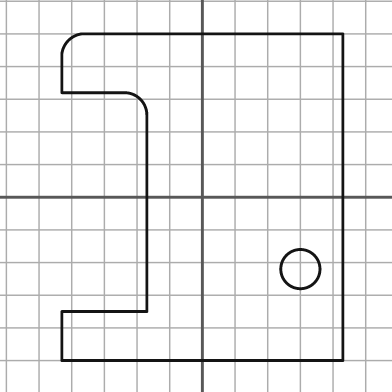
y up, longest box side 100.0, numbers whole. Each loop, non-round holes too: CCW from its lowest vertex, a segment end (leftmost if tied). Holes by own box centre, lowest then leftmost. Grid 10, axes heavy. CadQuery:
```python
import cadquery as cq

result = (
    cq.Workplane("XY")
    .moveTo(-43.0, -50.0)
    .lineTo(43.0, -50.0)
    .lineTo(43.0, 50.0)
    .lineTo(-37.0, 50.0)
    .threePointArc((-41.0, 48.0), (-43.0, 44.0))
    .lineTo(-43.0, 32.0)
    .lineTo(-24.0, 32.0)
    .threePointArc((-19.0, 30.0), (-17.0, 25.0))
    .lineTo(-17.0, -35.0)
    .lineTo(-43.0, -35.0)
    .close()
    .moveTo(30.0, -22.0)
    .circle(6.0)
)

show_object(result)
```